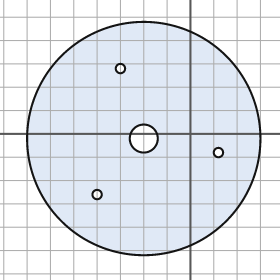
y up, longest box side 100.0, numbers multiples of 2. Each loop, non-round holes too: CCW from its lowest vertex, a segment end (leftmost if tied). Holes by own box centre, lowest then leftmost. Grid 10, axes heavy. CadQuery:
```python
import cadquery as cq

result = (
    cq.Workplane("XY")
    .moveTo(-20.0, -2.0)
    .circle(50.0)
    .moveTo(-40.0, -26.0)
    .circle(2.0)
    .moveTo(12.0, -8.0)
    .circle(2.0)
    .moveTo(-20.0, -2.0)
    .circle(6.0)
    .moveTo(-30.0, 28.0)
    .circle(2.0)
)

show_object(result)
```